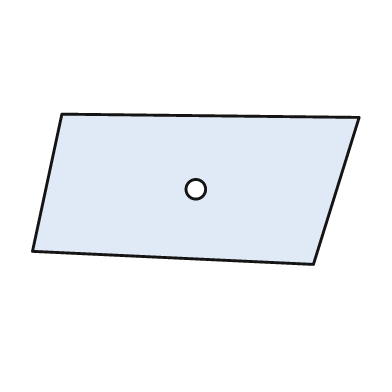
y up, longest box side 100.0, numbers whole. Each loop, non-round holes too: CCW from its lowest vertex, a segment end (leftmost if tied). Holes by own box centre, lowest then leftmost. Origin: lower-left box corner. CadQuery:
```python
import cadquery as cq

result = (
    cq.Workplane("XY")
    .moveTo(86.0, 0.0)
    .lineTo(100.0, 45.0)
    .lineTo(9.0, 46.0)
    .lineTo(0.0, 4.0)
    .close()
    .moveTo(50.0, 23.0)
    .circle(3.0)
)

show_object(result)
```